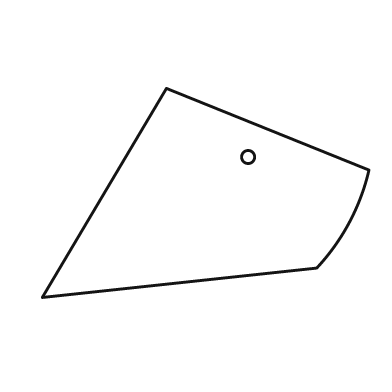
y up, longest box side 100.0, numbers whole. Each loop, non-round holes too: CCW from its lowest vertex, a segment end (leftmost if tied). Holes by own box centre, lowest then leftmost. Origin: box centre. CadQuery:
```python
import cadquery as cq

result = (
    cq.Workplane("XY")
    .moveTo(-50.0, -32.0)
    .lineTo(34.0, -23.0)
    .threePointArc((44.0, -9.0), (50.0, 7.0))
    .lineTo(-12.0, 32.0)
    .close()
    .moveTo(13.0, 11.0)
    .circle(2.0)
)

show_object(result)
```